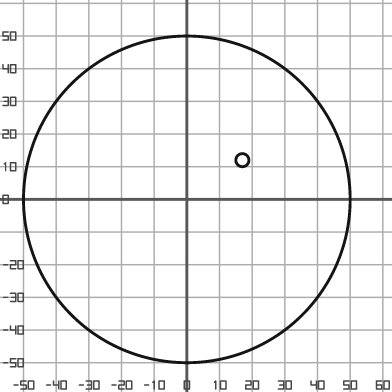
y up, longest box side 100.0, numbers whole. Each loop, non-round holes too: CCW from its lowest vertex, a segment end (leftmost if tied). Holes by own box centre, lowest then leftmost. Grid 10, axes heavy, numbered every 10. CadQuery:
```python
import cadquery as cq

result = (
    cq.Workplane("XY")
    .moveTo(0.0, 0.0)
    .circle(50.0)
    .moveTo(17.0, 12.0)
    .circle(2.0)
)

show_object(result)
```